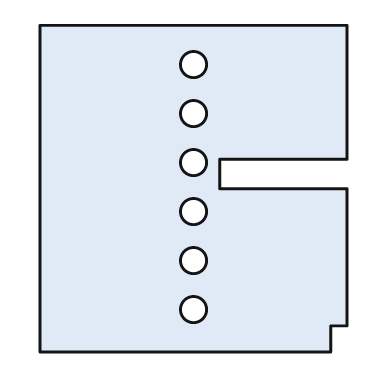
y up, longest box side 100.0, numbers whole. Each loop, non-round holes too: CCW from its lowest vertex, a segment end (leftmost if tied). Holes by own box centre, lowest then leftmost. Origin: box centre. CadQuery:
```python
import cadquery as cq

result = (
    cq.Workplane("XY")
    .moveTo(-47.0, -50.0)
    .lineTo(42.0, -50.0)
    .lineTo(42.0, -42.0)
    .lineTo(47.0, -42.0)
    .lineTo(47.0, 0.0)
    .lineTo(8.0, 0.0)
    .lineTo(8.0, 9.0)
    .lineTo(47.0, 9.0)
    .lineTo(47.0, 50.0)
    .lineTo(-47.0, 50.0)
    .close()
    .moveTo(0.0, -37.0)
    .circle(4.0)
    .moveTo(0.0, -22.0)
    .circle(4.0)
    .moveTo(0.0, -7.0)
    .circle(4.0)
    .moveTo(0.0, 8.0)
    .circle(4.0)
    .moveTo(0.0, 23.0)
    .circle(4.0)
    .moveTo(0.0, 38.0)
    .circle(4.0)
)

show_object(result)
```